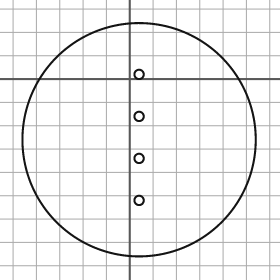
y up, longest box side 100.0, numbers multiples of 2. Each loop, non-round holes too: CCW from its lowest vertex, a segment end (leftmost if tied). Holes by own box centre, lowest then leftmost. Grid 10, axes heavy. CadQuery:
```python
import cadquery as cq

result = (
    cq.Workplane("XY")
    .moveTo(4.0, -26.0)
    .circle(50.0)
    .moveTo(4.0, -52.0)
    .circle(2.0)
    .moveTo(4.0, -34.0)
    .circle(2.0)
    .moveTo(4.0, -16.0)
    .circle(2.0)
    .moveTo(4.0, 2.0)
    .circle(2.0)
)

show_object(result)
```